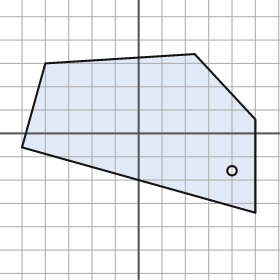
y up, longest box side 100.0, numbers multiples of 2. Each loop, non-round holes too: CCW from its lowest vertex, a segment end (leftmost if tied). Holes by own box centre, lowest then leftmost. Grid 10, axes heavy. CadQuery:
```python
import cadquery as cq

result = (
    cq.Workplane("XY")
    .moveTo(50.0, -34.0)
    .lineTo(50.0, 6.0)
    .lineTo(24.0, 34.0)
    .lineTo(-40.0, 30.0)
    .lineTo(-50.0, -6.0)
    .close()
    .moveTo(40.0, -16.0)
    .circle(2.0)
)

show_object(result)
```